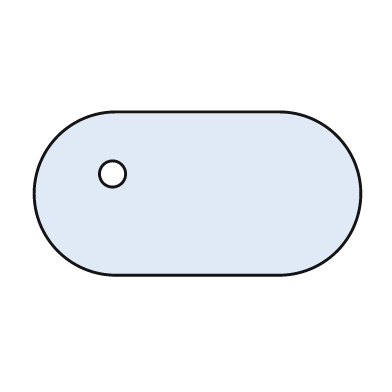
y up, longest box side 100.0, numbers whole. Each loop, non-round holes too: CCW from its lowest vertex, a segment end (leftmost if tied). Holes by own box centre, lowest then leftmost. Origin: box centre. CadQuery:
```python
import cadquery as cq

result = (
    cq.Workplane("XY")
    .moveTo(-25.0, -25.0)
    .lineTo(25.0, -25.0)
    .threePointArc((50.0, 0.0), (25.0, 25.0))
    .lineTo(-25.0, 25.0)
    .threePointArc((-50.0, 0.0), (-25.0, -25.0))
    .close()
    .moveTo(-26.0, 6.0)
    .circle(4.0)
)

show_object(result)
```